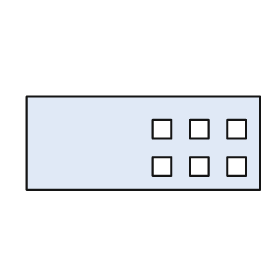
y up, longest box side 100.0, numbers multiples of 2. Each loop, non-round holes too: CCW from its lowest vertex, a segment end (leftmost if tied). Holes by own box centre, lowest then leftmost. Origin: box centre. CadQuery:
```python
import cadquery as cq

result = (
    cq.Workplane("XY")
    .moveTo(-50.0, -20.0)
    .lineTo(50.0, -20.0)
    .lineTo(50.0, 20.0)
    .lineTo(-50.0, 20.0)
    .close()
    .moveTo(4.0, -14.0)
    .lineTo(12.0, -14.0)
    .lineTo(12.0, -6.0)
    .lineTo(4.0, -6.0)
    .close()
    .moveTo(20.0, -14.0)
    .lineTo(28.0, -14.0)
    .lineTo(28.0, -6.0)
    .lineTo(20.0, -6.0)
    .close()
    .moveTo(36.0, -14.0)
    .lineTo(44.0, -14.0)
    .lineTo(44.0, -6.0)
    .lineTo(36.0, -6.0)
    .close()
    .moveTo(4.0, 2.0)
    .lineTo(12.0, 2.0)
    .lineTo(12.0, 10.0)
    .lineTo(4.0, 10.0)
    .close()
    .moveTo(20.0, 2.0)
    .lineTo(28.0, 2.0)
    .lineTo(28.0, 10.0)
    .lineTo(20.0, 10.0)
    .close()
    .moveTo(36.0, 2.0)
    .lineTo(44.0, 2.0)
    .lineTo(44.0, 10.0)
    .lineTo(36.0, 10.0)
    .close()
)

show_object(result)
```